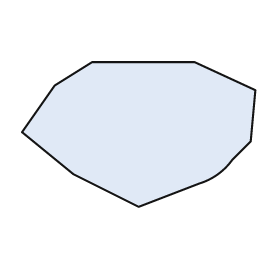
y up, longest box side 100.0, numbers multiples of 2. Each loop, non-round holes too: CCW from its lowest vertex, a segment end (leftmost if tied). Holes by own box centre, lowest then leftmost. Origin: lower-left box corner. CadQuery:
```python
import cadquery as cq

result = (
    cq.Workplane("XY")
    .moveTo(50.0, 0.0)
    .lineTo(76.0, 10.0)
    .threePointArc((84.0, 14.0), (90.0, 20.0))
    .lineTo(98.0, 28.0)
    .lineTo(100.0, 50.0)
    .lineTo(74.0, 62.0)
    .lineTo(30.0, 62.0)
    .lineTo(14.0, 52.0)
    .lineTo(0.0, 32.0)
    .lineTo(22.0, 14.0)
    .close()
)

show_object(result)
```